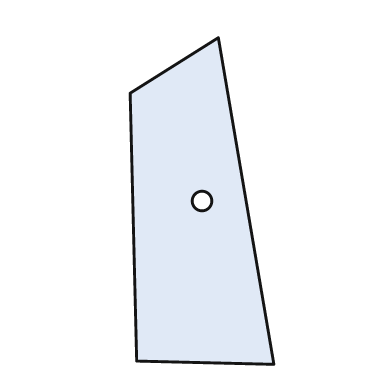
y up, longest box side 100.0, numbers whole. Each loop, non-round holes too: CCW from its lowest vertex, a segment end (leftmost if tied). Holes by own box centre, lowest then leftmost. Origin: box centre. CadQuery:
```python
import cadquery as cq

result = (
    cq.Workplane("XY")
    .moveTo(22.0, -50.0)
    .lineTo(5.0, 50.0)
    .lineTo(-22.0, 33.0)
    .lineTo(-20.0, -49.0)
    .close()
    .moveTo(0.0, 0.0)
    .circle(3.0)
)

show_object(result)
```